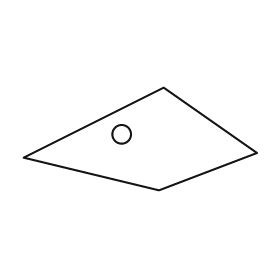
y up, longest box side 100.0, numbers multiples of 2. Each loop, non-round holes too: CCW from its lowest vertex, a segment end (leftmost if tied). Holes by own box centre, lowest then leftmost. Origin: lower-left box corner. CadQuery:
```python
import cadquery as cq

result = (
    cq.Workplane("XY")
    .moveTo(58.0, 0.0)
    .lineTo(100.0, 16.0)
    .lineTo(60.0, 44.0)
    .lineTo(0.0, 14.0)
    .close()
    .moveTo(42.0, 24.0)
    .circle(4.0)
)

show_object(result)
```